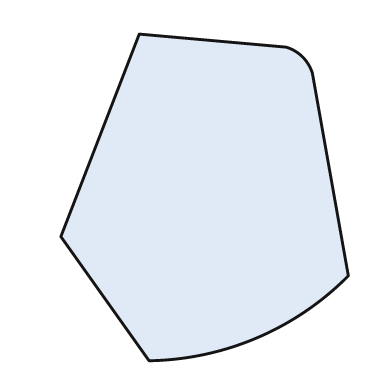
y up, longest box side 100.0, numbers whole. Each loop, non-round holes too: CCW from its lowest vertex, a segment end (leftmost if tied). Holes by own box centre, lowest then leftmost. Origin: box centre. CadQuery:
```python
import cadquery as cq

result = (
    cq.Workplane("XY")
    .moveTo(-17.0, -50.0)
    .threePointArc((16.0, -43.0), (44.0, -24.0))
    .lineTo(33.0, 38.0)
    .threePointArc((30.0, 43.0), (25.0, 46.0))
    .lineTo(-20.0, 50.0)
    .lineTo(-44.0, -12.0)
    .close()
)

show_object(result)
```